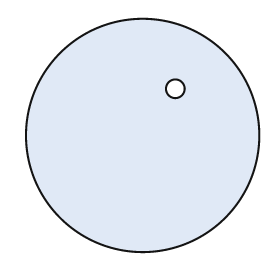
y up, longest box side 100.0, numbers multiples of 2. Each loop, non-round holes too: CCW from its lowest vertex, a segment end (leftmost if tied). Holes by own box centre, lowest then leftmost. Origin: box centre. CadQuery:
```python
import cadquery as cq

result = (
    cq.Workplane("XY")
    .moveTo(0.0, 0.0)
    .circle(50.0)
    .moveTo(14.0, 20.0)
    .circle(4.0)
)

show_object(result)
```